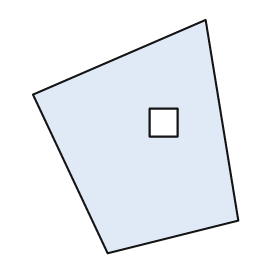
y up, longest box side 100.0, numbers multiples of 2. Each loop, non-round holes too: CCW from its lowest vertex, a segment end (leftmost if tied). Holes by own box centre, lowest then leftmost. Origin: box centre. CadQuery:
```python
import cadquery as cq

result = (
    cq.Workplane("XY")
    .moveTo(-12.0, -50.0)
    .lineTo(44.0, -36.0)
    .lineTo(30.0, 50.0)
    .lineTo(-44.0, 18.0)
    .close()
    .moveTo(6.0, 0.0)
    .lineTo(18.0, 0.0)
    .lineTo(18.0, 12.0)
    .lineTo(6.0, 12.0)
    .close()
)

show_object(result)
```